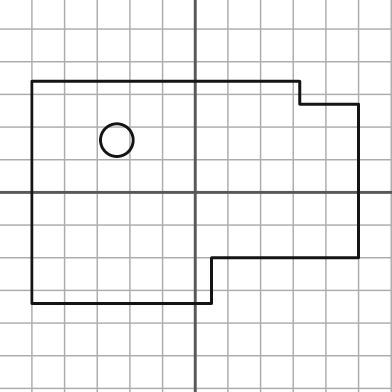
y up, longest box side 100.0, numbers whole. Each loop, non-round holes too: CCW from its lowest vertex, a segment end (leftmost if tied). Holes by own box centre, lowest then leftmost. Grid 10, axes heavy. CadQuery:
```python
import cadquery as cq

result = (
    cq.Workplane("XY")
    .moveTo(-50.0, -34.0)
    .lineTo(5.0, -34.0)
    .lineTo(5.0, -20.0)
    .lineTo(50.0, -20.0)
    .lineTo(50.0, 27.0)
    .lineTo(32.0, 27.0)
    .lineTo(32.0, 34.0)
    .lineTo(-50.0, 34.0)
    .close()
    .moveTo(-24.0, 16.0)
    .circle(5.0)
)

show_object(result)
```